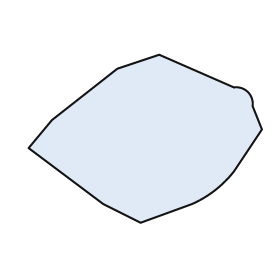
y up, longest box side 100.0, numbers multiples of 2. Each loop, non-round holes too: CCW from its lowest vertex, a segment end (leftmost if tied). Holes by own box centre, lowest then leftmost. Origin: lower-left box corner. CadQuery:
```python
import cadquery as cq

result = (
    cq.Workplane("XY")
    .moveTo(48.0, 0.0)
    .lineTo(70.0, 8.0)
    .threePointArc((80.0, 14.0), (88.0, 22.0))
    .lineTo(100.0, 40.0)
    .lineTo(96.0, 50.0)
    .threePointArc((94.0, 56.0), (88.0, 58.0))
    .lineTo(56.0, 72.0)
    .lineTo(38.0, 66.0)
    .lineTo(10.0, 44.0)
    .lineTo(0.0, 32.0)
    .lineTo(32.0, 8.0)
    .close()
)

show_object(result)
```